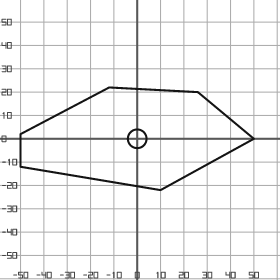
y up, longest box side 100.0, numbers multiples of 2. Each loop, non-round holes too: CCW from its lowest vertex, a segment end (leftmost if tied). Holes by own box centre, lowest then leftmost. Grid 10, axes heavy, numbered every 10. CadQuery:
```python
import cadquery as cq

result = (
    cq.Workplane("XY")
    .moveTo(10.0, -22.0)
    .lineTo(50.0, 0.0)
    .lineTo(26.0, 20.0)
    .lineTo(-12.0, 22.0)
    .lineTo(-50.0, 2.0)
    .lineTo(-50.0, -12.0)
    .close()
    .moveTo(0.0, 0.0)
    .circle(4.0)
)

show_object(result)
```